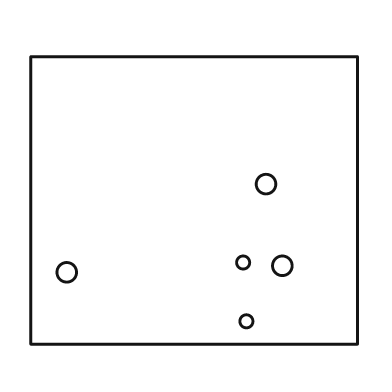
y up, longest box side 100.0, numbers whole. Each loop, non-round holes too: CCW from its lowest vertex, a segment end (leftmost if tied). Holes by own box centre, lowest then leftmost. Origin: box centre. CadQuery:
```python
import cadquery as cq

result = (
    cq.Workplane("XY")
    .moveTo(-50.0, -44.0)
    .lineTo(50.0, -44.0)
    .lineTo(50.0, 44.0)
    .lineTo(-50.0, 44.0)
    .close()
    .moveTo(16.0, -37.0)
    .circle(2.0)
    .moveTo(-39.0, -22.0)
    .circle(3.0)
    .moveTo(27.0, -20.0)
    .circle(3.0)
    .moveTo(15.0, -19.0)
    .circle(2.0)
    .moveTo(22.0, 5.0)
    .circle(3.0)
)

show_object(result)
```